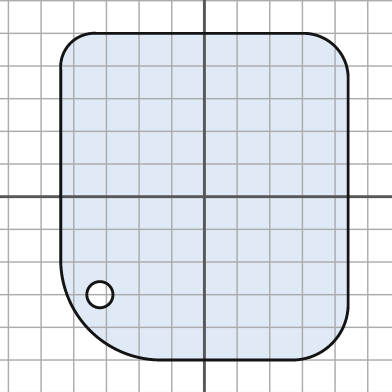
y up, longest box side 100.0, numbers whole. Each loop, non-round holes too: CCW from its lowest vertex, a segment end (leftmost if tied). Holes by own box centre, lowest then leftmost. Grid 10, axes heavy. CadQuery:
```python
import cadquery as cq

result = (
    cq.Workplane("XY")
    .moveTo(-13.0, -50.0)
    .lineTo(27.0, -50.0)
    .threePointArc((39.0, -45.0), (44.0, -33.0))
    .lineTo(44.0, 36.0)
    .threePointArc((40.0, 46.0), (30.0, 50.0))
    .lineTo(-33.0, 50.0)
    .threePointArc((-41.0, 47.0), (-44.0, 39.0))
    .lineTo(-44.0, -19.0)
    .threePointArc((-35.0, -41.0), (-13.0, -50.0))
    .close()
    .moveTo(-32.0, -30.0)
    .circle(4.0)
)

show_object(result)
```